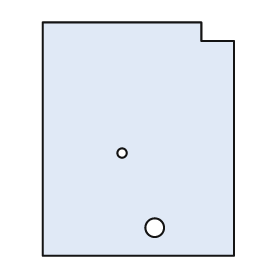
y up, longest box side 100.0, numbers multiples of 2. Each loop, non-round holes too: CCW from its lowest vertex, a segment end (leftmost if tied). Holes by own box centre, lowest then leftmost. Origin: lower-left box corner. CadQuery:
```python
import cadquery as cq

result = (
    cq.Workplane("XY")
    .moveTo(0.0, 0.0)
    .lineTo(82.0, 0.0)
    .lineTo(82.0, 92.0)
    .lineTo(68.0, 92.0)
    .lineTo(68.0, 100.0)
    .lineTo(0.0, 100.0)
    .close()
    .moveTo(48.0, 12.0)
    .circle(4.0)
    .moveTo(34.0, 44.0)
    .circle(2.0)
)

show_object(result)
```